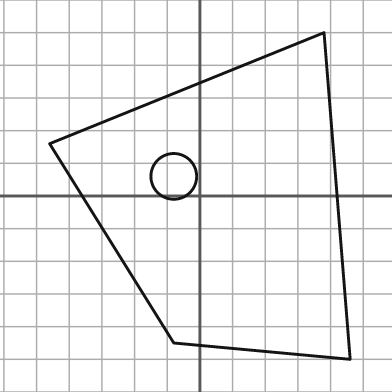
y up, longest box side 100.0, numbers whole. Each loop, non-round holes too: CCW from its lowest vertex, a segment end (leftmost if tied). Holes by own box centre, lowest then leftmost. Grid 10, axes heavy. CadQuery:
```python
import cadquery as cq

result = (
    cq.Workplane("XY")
    .moveTo(46.0, -50.0)
    .lineTo(38.0, 50.0)
    .lineTo(-46.0, 16.0)
    .lineTo(-8.0, -45.0)
    .close()
    .moveTo(-8.0, 6.0)
    .circle(7.0)
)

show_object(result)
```